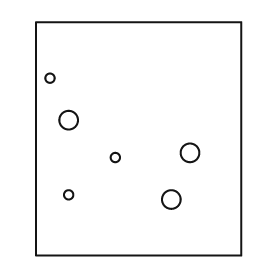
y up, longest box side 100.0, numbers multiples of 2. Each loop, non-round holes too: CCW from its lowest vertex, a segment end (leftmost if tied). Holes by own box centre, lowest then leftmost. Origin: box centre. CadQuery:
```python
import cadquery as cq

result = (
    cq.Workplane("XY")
    .moveTo(-44.0, -50.0)
    .lineTo(44.0, -50.0)
    .lineTo(44.0, 50.0)
    .lineTo(-44.0, 50.0)
    .close()
    .moveTo(14.0, -26.0)
    .circle(4.0)
    .moveTo(-30.0, -24.0)
    .circle(2.0)
    .moveTo(-10.0, -8.0)
    .circle(2.0)
    .moveTo(22.0, -6.0)
    .circle(4.0)
    .moveTo(-30.0, 8.0)
    .circle(4.0)
    .moveTo(-38.0, 26.0)
    .circle(2.0)
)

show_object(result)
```